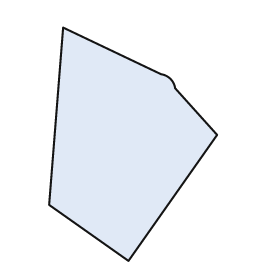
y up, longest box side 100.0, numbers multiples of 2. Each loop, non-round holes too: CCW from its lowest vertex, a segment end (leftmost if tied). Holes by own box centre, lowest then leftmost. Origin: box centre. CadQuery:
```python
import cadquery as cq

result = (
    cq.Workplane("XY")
    .moveTo(-2.0, -50.0)
    .lineTo(36.0, 4.0)
    .lineTo(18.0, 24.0)
    .threePointArc((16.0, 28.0), (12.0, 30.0))
    .lineTo(-30.0, 50.0)
    .lineTo(-36.0, -26.0)
    .close()
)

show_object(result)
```